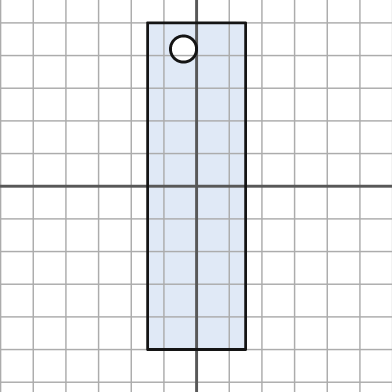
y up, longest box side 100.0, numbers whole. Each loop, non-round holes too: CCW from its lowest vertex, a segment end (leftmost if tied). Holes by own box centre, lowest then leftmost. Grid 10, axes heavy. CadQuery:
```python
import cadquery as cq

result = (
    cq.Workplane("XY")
    .moveTo(-15.0, -50.0)
    .lineTo(15.0, -50.0)
    .lineTo(15.0, 50.0)
    .lineTo(-15.0, 50.0)
    .close()
    .moveTo(-4.0, 42.0)
    .circle(4.0)
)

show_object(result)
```